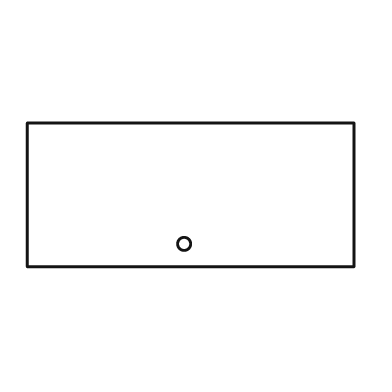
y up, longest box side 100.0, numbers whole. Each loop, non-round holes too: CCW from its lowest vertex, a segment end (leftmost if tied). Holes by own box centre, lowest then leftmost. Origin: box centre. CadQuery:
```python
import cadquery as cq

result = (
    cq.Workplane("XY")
    .moveTo(-50.0, -22.0)
    .lineTo(50.0, -22.0)
    .lineTo(50.0, 22.0)
    .lineTo(-50.0, 22.0)
    .close()
    .moveTo(-2.0, -15.0)
    .circle(2.0)
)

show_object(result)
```